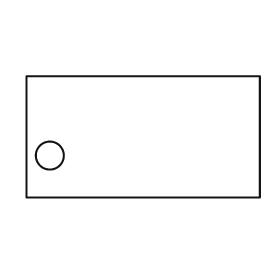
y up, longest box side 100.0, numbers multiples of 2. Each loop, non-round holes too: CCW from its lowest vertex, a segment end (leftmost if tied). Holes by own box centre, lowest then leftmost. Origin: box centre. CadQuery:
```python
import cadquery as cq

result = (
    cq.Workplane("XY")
    .moveTo(-50.0, -26.0)
    .lineTo(50.0, -26.0)
    .lineTo(50.0, 26.0)
    .lineTo(-50.0, 26.0)
    .close()
    .moveTo(-40.0, -8.0)
    .circle(6.0)
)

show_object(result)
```